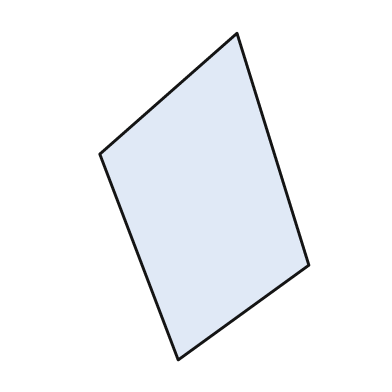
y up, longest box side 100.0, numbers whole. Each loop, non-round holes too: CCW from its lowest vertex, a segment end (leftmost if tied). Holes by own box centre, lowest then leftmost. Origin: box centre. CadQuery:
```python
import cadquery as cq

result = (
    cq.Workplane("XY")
    .moveTo(-8.0, -50.0)
    .lineTo(32.0, -21.0)
    .lineTo(10.0, 50.0)
    .lineTo(-32.0, 13.0)
    .close()
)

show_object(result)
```